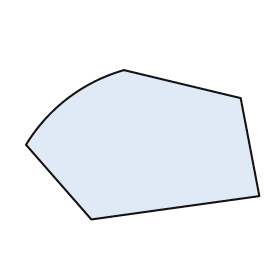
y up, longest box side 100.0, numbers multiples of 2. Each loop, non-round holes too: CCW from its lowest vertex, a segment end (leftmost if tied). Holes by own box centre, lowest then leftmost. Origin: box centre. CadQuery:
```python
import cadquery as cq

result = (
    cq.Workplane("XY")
    .moveTo(-22.0, -32.0)
    .lineTo(50.0, -22.0)
    .lineTo(42.0, 20.0)
    .lineTo(-8.0, 32.0)
    .threePointArc((-32.0, 20.0), (-50.0, 0.0))
    .close()
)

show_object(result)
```